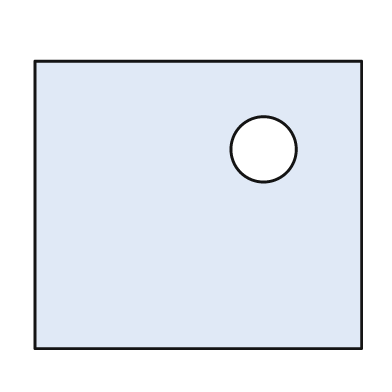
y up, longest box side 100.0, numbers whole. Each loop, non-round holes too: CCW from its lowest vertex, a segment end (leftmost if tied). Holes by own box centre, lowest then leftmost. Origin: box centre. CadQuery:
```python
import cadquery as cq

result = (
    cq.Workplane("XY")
    .moveTo(-50.0, -44.0)
    .lineTo(50.0, -44.0)
    .lineTo(50.0, 44.0)
    .lineTo(-50.0, 44.0)
    .close()
    .moveTo(20.0, 17.0)
    .circle(10.0)
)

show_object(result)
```